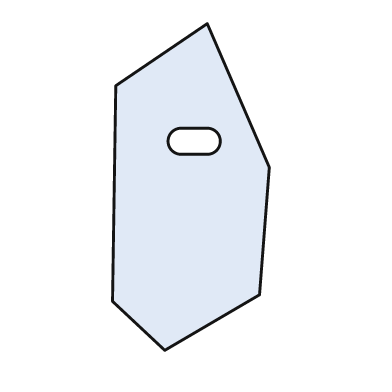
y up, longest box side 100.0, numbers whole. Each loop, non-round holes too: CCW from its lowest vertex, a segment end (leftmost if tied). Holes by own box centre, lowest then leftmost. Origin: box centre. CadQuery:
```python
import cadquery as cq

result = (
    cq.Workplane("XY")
    .moveTo(-8.0, -50.0)
    .lineTo(21.0, -33.0)
    .lineTo(24.0, 6.0)
    .lineTo(5.0, 50.0)
    .lineTo(-23.0, 31.0)
    .lineTo(-24.0, -35.0)
    .close()
    .moveTo(-3.0, 10.0)
    .lineTo(5.0, 10.0)
    .threePointArc((9.0, 14.0), (5.0, 18.0))
    .lineTo(-3.0, 18.0)
    .threePointArc((-7.0, 14.0), (-3.0, 10.0))
    .close()
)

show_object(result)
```